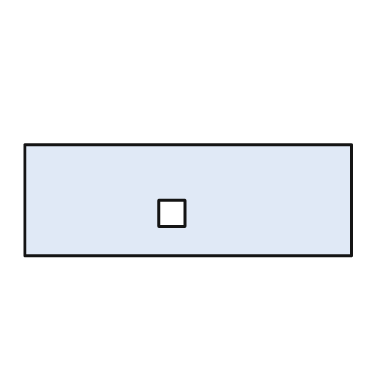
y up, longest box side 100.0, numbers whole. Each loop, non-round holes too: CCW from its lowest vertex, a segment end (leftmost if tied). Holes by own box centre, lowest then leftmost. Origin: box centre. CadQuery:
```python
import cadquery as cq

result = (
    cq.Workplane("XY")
    .moveTo(-50.0, -17.0)
    .lineTo(50.0, -17.0)
    .lineTo(50.0, 17.0)
    .lineTo(-50.0, 17.0)
    .close()
    .moveTo(-9.0, -8.0)
    .lineTo(-1.0, -8.0)
    .lineTo(-1.0, 0.0)
    .lineTo(-9.0, 0.0)
    .close()
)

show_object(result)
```